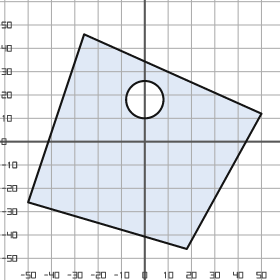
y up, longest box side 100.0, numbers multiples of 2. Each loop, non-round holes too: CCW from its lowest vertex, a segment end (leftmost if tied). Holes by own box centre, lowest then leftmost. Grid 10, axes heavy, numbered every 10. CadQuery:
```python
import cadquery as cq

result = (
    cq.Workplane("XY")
    .moveTo(18.0, -46.0)
    .lineTo(50.0, 12.0)
    .lineTo(-26.0, 46.0)
    .lineTo(-50.0, -26.0)
    .close()
    .moveTo(0.0, 18.0)
    .circle(8.0)
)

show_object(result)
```